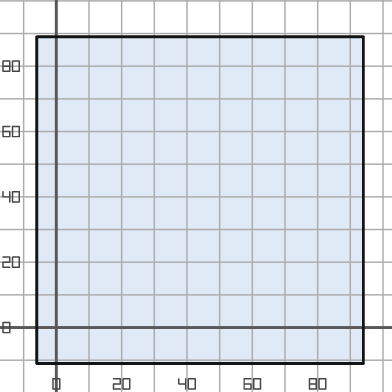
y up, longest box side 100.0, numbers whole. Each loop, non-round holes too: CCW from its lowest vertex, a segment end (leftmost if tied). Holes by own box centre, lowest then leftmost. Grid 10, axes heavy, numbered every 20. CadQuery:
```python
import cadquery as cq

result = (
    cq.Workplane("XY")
    .moveTo(-6.0, -11.0)
    .lineTo(94.0, -11.0)
    .lineTo(94.0, 89.0)
    .lineTo(-6.0, 89.0)
    .close()
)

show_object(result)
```